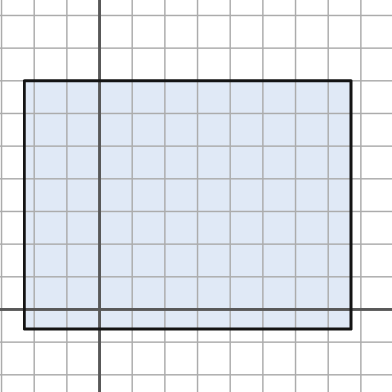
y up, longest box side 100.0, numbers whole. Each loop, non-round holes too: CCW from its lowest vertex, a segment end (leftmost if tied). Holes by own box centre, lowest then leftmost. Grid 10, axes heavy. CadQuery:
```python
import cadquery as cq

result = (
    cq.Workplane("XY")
    .moveTo(-23.0, -6.0)
    .lineTo(77.0, -6.0)
    .lineTo(77.0, 70.0)
    .lineTo(-23.0, 70.0)
    .close()
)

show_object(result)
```